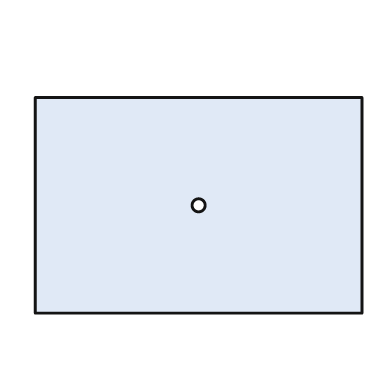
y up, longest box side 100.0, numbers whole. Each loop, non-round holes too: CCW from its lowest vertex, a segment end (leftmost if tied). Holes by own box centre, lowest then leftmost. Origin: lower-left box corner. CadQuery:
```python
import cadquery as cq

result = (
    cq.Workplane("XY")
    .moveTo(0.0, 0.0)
    .lineTo(100.0, 0.0)
    .lineTo(100.0, 66.0)
    .lineTo(0.0, 66.0)
    .close()
    .moveTo(50.0, 33.0)
    .circle(2.0)
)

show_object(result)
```